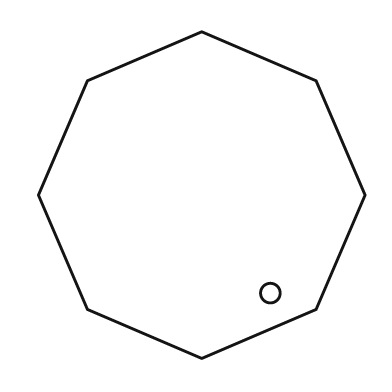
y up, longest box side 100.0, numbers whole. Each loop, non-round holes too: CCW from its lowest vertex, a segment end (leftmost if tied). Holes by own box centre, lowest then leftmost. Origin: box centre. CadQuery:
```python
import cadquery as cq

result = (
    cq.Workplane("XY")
    .moveTo(0.0, -50.0)
    .lineTo(35.0, -35.0)
    .lineTo(50.0, 0.0)
    .lineTo(35.0, 35.0)
    .lineTo(0.0, 50.0)
    .lineTo(-35.0, 35.0)
    .lineTo(-50.0, 0.0)
    .lineTo(-35.0, -35.0)
    .close()
    .moveTo(21.0, -30.0)
    .circle(3.0)
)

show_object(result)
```